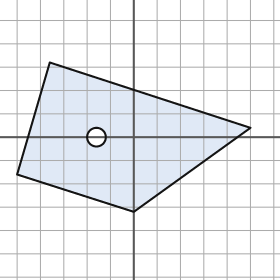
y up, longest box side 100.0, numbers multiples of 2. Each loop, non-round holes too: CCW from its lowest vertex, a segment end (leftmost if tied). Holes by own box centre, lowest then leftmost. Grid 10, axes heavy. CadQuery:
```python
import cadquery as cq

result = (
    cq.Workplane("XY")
    .moveTo(0.0, -32.0)
    .lineTo(50.0, 4.0)
    .lineTo(-36.0, 32.0)
    .lineTo(-50.0, -16.0)
    .close()
    .moveTo(-16.0, 0.0)
    .circle(4.0)
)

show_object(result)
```